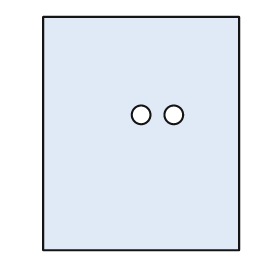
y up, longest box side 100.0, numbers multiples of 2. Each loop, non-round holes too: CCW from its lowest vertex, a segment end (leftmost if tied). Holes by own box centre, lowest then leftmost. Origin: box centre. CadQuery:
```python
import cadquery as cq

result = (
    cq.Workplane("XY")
    .moveTo(-42.0, -50.0)
    .lineTo(42.0, -50.0)
    .lineTo(42.0, 50.0)
    .lineTo(-42.0, 50.0)
    .close()
    .moveTo(0.0, 8.0)
    .circle(4.0)
    .moveTo(14.0, 8.0)
    .circle(4.0)
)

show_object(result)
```